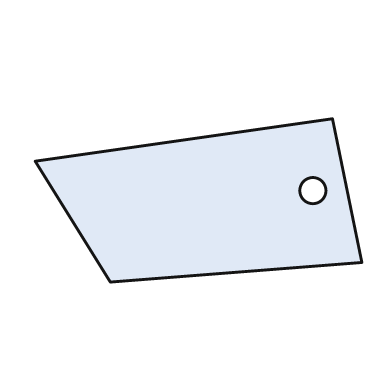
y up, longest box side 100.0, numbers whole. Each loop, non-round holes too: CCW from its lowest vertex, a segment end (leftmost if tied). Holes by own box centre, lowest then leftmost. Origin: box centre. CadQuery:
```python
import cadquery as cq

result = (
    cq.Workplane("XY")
    .moveTo(-27.0, -25.0)
    .lineTo(50.0, -19.0)
    .lineTo(41.0, 25.0)
    .lineTo(-50.0, 12.0)
    .close()
    .moveTo(35.0, 3.0)
    .circle(4.0)
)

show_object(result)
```